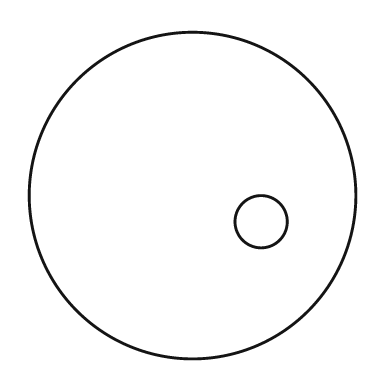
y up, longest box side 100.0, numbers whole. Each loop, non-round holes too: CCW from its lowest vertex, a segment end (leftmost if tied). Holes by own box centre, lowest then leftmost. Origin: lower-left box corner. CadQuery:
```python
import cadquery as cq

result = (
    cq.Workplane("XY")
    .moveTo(50.0, 50.0)
    .circle(50.0)
    .moveTo(71.0, 42.0)
    .circle(8.0)
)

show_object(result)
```